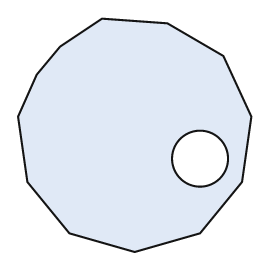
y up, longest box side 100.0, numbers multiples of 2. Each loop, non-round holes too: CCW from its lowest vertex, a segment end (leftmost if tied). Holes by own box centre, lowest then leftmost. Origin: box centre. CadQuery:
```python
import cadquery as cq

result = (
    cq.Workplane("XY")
    .moveTo(0.0, -50.0)
    .lineTo(28.0, -42.0)
    .lineTo(46.0, -20.0)
    .lineTo(50.0, 8.0)
    .lineTo(38.0, 34.0)
    .lineTo(14.0, 48.0)
    .lineTo(-14.0, 50.0)
    .lineTo(-32.0, 38.0)
    .lineTo(-42.0, 26.0)
    .lineTo(-50.0, 8.0)
    .lineTo(-46.0, -20.0)
    .lineTo(-28.0, -42.0)
    .close()
    .moveTo(28.0, -10.0)
    .circle(12.0)
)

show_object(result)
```